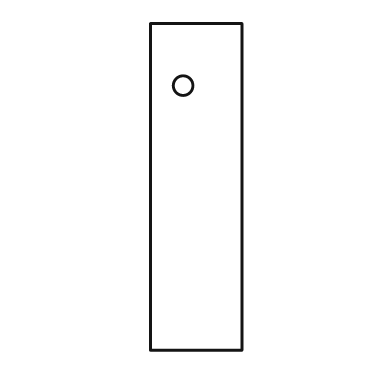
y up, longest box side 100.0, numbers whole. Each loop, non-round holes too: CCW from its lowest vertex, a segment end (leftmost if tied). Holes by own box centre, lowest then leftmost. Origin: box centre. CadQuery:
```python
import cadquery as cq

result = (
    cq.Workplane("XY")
    .moveTo(-14.0, -50.0)
    .lineTo(14.0, -50.0)
    .lineTo(14.0, 50.0)
    .lineTo(-14.0, 50.0)
    .close()
    .moveTo(-4.0, 31.0)
    .circle(3.0)
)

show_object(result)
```